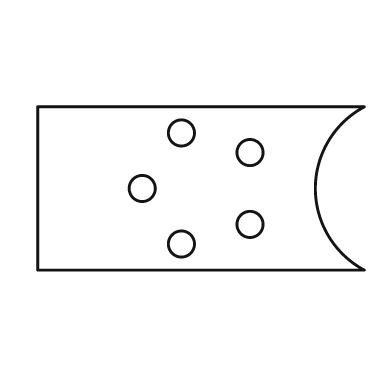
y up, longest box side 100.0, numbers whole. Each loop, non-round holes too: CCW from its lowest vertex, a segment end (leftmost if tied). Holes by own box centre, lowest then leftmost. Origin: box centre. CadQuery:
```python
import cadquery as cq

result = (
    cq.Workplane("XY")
    .moveTo(-50.0, -25.0)
    .lineTo(50.0, -25.0)
    .threePointArc((35.0, 0.0), (50.0, 25.0))
    .lineTo(-50.0, 25.0)
    .close()
    .moveTo(-6.0, -17.0)
    .circle(4.0)
    .moveTo(15.0, -11.0)
    .circle(4.0)
    .moveTo(-18.0, 0.0)
    .circle(4.0)
    .moveTo(15.0, 11.0)
    .circle(4.0)
    .moveTo(-6.0, 17.0)
    .circle(4.0)
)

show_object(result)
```